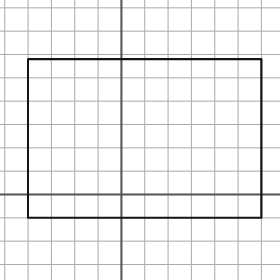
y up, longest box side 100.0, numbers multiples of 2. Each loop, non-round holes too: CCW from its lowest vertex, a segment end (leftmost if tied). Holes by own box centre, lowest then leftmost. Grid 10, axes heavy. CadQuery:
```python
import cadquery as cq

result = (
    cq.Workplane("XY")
    .moveTo(-40.0, -10.0)
    .lineTo(60.0, -10.0)
    .lineTo(60.0, 58.0)
    .lineTo(-40.0, 58.0)
    .close()
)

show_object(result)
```